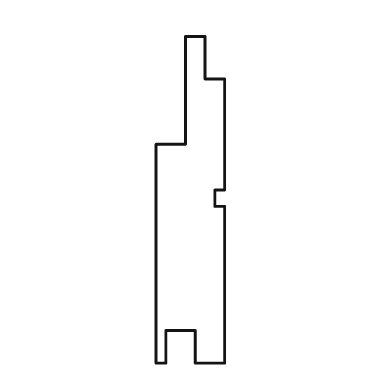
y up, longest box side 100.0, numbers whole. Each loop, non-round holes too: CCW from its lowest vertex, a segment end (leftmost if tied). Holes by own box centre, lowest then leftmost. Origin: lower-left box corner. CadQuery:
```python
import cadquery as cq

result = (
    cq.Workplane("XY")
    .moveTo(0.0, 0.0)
    .lineTo(3.0, 0.0)
    .lineTo(3.0, 10.0)
    .lineTo(12.0, 10.0)
    .lineTo(12.0, 0.0)
    .lineTo(21.0, 0.0)
    .lineTo(21.0, 48.0)
    .lineTo(18.0, 48.0)
    .lineTo(18.0, 53.0)
    .lineTo(21.0, 53.0)
    .lineTo(21.0, 87.0)
    .lineTo(15.0, 87.0)
    .lineTo(15.0, 100.0)
    .lineTo(9.0, 100.0)
    .lineTo(9.0, 67.0)
    .lineTo(0.0, 67.0)
    .close()
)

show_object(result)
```